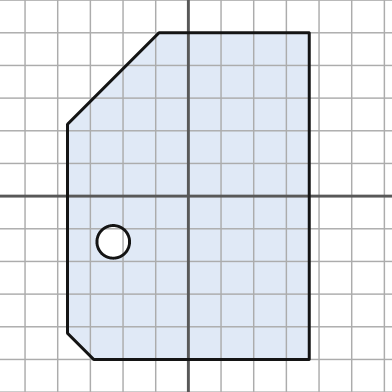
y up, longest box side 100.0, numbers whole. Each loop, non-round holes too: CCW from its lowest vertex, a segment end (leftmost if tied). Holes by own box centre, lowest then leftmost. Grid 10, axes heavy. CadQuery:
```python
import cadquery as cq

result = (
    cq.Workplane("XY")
    .moveTo(-29.0, -50.0)
    .lineTo(37.0, -50.0)
    .lineTo(37.0, 50.0)
    .lineTo(-9.0, 50.0)
    .lineTo(-37.0, 22.0)
    .lineTo(-37.0, -42.0)
    .close()
    .moveTo(-23.0, -14.0)
    .circle(5.0)
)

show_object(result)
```